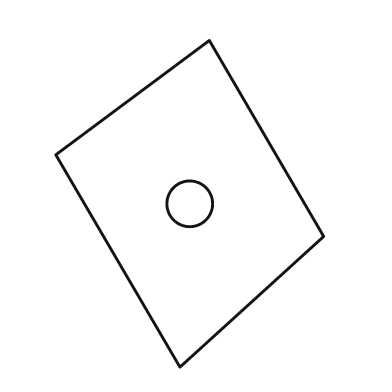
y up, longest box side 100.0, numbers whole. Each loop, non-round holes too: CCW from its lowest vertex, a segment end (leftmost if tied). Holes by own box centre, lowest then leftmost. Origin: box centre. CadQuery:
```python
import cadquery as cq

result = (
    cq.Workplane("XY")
    .moveTo(-3.0, -50.0)
    .lineTo(41.0, -10.0)
    .lineTo(6.0, 50.0)
    .lineTo(-41.0, 15.0)
    .close()
    .moveTo(0.0, 0.0)
    .circle(7.0)
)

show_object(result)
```